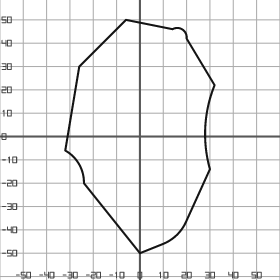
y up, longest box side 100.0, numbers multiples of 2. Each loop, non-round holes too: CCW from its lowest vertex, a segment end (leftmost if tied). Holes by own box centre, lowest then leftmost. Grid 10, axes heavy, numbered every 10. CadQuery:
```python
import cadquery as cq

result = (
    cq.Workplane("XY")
    .moveTo(0.0, -50.0)
    .lineTo(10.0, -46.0)
    .threePointArc((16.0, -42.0), (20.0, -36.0))
    .lineTo(30.0, -14.0)
    .threePointArc((28.0, 4.0), (32.0, 22.0))
    .lineTo(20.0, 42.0)
    .threePointArc((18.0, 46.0), (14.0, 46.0))
    .lineTo(-6.0, 50.0)
    .lineTo(-26.0, 30.0)
    .lineTo(-32.0, -6.0)
    .threePointArc((-26.0, -12.0), (-24.0, -20.0))
    .close()
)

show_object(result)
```